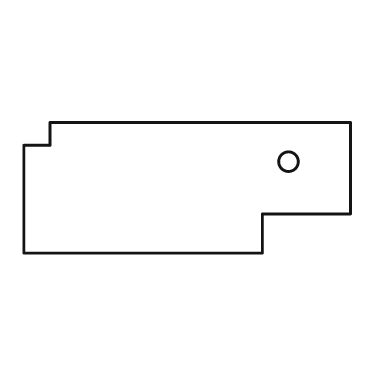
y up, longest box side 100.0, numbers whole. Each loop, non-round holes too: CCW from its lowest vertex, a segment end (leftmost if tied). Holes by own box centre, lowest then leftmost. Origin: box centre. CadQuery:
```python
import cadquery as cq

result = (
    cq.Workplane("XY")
    .moveTo(-50.0, -20.0)
    .lineTo(23.0, -20.0)
    .lineTo(23.0, -8.0)
    .lineTo(50.0, -8.0)
    .lineTo(50.0, 20.0)
    .lineTo(-42.0, 20.0)
    .lineTo(-42.0, 13.0)
    .lineTo(-50.0, 13.0)
    .close()
    .moveTo(31.0, 8.0)
    .circle(3.0)
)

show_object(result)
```